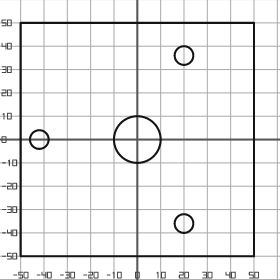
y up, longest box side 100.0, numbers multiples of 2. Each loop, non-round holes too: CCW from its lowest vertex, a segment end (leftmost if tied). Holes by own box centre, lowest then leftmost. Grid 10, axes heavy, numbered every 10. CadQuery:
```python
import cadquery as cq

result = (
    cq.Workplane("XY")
    .moveTo(-50.0, -50.0)
    .lineTo(50.0, -50.0)
    .lineTo(50.0, 50.0)
    .lineTo(-50.0, 50.0)
    .close()
    .moveTo(20.0, -36.0)
    .circle(4.0)
    .moveTo(-42.0, 0.0)
    .circle(4.0)
    .moveTo(0.0, 0.0)
    .circle(10.0)
    .moveTo(20.0, 36.0)
    .circle(4.0)
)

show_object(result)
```